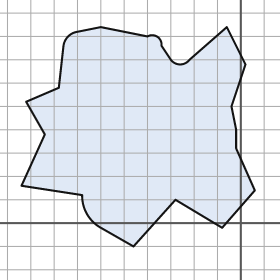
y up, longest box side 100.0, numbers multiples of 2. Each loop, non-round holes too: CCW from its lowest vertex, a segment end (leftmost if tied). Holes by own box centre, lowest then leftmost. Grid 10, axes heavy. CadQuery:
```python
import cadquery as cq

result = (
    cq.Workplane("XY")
    .moveTo(-46.0, -10.0)
    .lineTo(-28.0, 10.0)
    .lineTo(-8.0, -2.0)
    .lineTo(6.0, 14.0)
    .lineTo(-2.0, 32.0)
    .lineTo(-2.0, 40.0)
    .lineTo(-4.0, 50.0)
    .lineTo(2.0, 68.0)
    .lineTo(-6.0, 84.0)
    .lineTo(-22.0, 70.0)
    .threePointArc((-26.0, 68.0), (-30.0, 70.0))
    .lineTo(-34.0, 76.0)
    .threePointArc((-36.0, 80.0), (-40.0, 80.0))
    .lineTo(-60.0, 84.0)
    .lineTo(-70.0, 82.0)
    .threePointArc((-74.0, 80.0), (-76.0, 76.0))
    .lineTo(-78.0, 58.0)
    .lineTo(-92.0, 52.0)
    .lineTo(-84.0, 38.0)
    .lineTo(-94.0, 16.0)
    .lineTo(-68.0, 12.0)
    .threePointArc((-66.0, 4.0), (-60.0, -2.0))
    .close()
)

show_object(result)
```